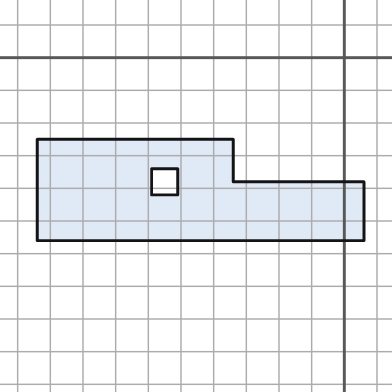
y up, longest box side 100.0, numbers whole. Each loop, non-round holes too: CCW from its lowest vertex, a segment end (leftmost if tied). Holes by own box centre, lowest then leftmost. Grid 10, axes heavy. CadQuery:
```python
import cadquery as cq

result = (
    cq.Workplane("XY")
    .moveTo(-94.0, -56.0)
    .lineTo(6.0, -56.0)
    .lineTo(6.0, -38.0)
    .lineTo(-34.0, -38.0)
    .lineTo(-34.0, -25.0)
    .lineTo(-94.0, -25.0)
    .close()
    .moveTo(-59.0, -42.0)
    .lineTo(-51.0, -42.0)
    .lineTo(-51.0, -34.0)
    .lineTo(-59.0, -34.0)
    .close()
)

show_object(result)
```